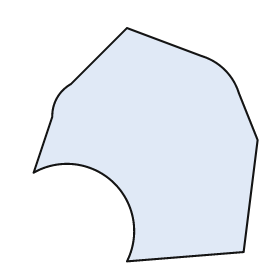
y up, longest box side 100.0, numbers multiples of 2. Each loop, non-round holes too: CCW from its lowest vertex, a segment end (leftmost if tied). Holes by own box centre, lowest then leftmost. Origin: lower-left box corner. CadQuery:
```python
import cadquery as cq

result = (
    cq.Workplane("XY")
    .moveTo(40.0, 0.0)
    .lineTo(90.0, 4.0)
    .lineTo(96.0, 52.0)
    .lineTo(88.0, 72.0)
    .threePointArc((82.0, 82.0), (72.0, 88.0))
    .lineTo(40.0, 100.0)
    .lineTo(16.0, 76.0)
    .threePointArc((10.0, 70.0), (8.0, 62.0))
    .lineTo(0.0, 38.0)
    .threePointArc((34.0, 34.0), (40.0, 0.0))
    .close()
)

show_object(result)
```